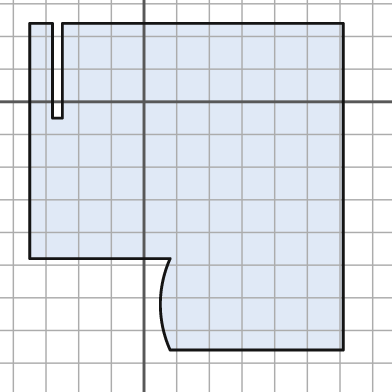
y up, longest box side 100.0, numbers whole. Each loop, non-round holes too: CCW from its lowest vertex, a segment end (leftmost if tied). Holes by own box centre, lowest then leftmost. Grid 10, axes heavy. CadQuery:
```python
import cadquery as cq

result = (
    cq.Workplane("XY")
    .moveTo(8.0, -76.0)
    .lineTo(61.0, -76.0)
    .lineTo(61.0, 24.0)
    .lineTo(-25.0, 24.0)
    .lineTo(-25.0, -5.0)
    .lineTo(-28.0, -5.0)
    .lineTo(-28.0, 24.0)
    .lineTo(-35.0, 24.0)
    .lineTo(-35.0, -48.0)
    .lineTo(8.0, -48.0)
    .threePointArc((5.0, -62.0), (8.0, -76.0))
    .close()
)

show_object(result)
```